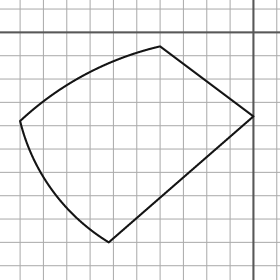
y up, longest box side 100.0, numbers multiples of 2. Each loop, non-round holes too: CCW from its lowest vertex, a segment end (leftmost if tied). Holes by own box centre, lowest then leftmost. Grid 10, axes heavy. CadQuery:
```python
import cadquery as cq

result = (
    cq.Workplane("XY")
    .moveTo(-62.0, -90.0)
    .lineTo(0.0, -36.0)
    .lineTo(-40.0, -6.0)
    .threePointArc((-72.0, -18.0), (-100.0, -38.0))
    .threePointArc((-86.0, -68.0), (-62.0, -90.0))
    .close()
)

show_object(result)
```